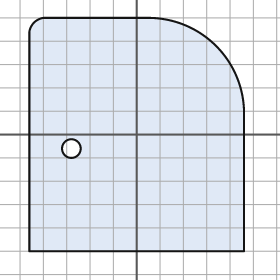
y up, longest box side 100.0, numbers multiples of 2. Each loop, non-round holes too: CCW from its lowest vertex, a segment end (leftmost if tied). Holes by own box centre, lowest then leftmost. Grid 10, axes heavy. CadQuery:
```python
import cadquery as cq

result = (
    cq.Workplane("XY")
    .moveTo(-46.0, -50.0)
    .lineTo(46.0, -50.0)
    .lineTo(46.0, 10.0)
    .threePointArc((34.0, 38.0), (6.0, 50.0))
    .lineTo(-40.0, 50.0)
    .threePointArc((-44.0, 48.0), (-46.0, 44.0))
    .close()
    .moveTo(-28.0, -6.0)
    .circle(4.0)
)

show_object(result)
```